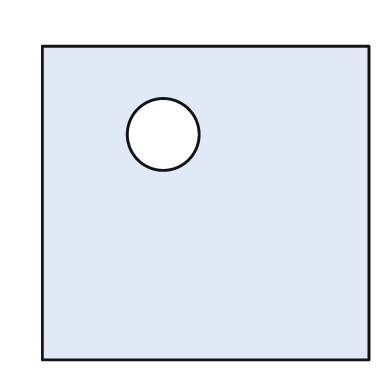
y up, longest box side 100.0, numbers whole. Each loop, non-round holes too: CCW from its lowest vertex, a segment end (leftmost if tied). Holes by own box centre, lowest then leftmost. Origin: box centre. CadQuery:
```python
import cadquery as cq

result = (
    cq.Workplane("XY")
    .moveTo(-50.0, -48.0)
    .lineTo(50.0, -48.0)
    .lineTo(50.0, 48.0)
    .lineTo(-50.0, 48.0)
    .close()
    .moveTo(-13.0, 21.0)
    .circle(11.0)
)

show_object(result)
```